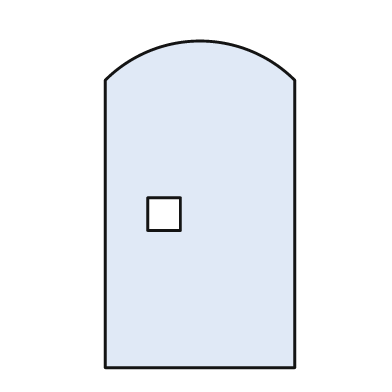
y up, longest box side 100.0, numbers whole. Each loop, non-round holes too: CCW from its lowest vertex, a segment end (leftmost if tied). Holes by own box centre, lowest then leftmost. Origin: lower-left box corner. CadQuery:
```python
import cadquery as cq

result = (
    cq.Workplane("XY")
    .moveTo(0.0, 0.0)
    .lineTo(58.0, 0.0)
    .lineTo(58.0, 88.0)
    .threePointArc((29.0, 100.0), (0.0, 88.0))
    .close()
    .moveTo(13.0, 42.0)
    .lineTo(23.0, 42.0)
    .lineTo(23.0, 52.0)
    .lineTo(13.0, 52.0)
    .close()
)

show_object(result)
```